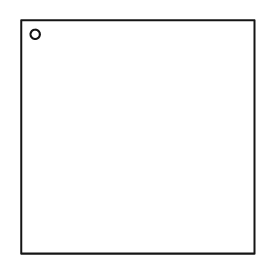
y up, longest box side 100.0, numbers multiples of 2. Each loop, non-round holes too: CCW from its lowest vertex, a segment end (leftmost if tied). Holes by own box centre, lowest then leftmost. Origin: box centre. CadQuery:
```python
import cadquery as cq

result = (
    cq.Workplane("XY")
    .moveTo(-50.0, -50.0)
    .lineTo(50.0, -50.0)
    .lineTo(50.0, 50.0)
    .lineTo(-50.0, 50.0)
    .close()
    .moveTo(-44.0, 44.0)
    .circle(2.0)
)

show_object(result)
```